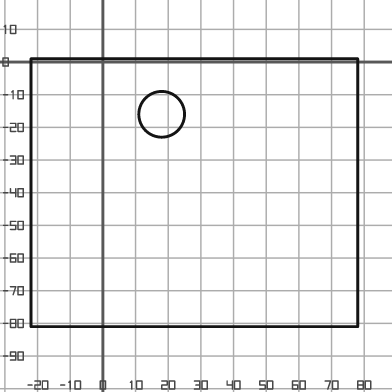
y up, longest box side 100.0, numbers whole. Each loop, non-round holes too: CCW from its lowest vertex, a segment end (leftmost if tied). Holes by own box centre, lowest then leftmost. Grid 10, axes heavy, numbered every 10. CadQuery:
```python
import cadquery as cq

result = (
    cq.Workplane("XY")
    .moveTo(-22.0, -81.0)
    .lineTo(78.0, -81.0)
    .lineTo(78.0, 1.0)
    .lineTo(-22.0, 1.0)
    .close()
    .moveTo(18.0, -16.0)
    .circle(7.0)
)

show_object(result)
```